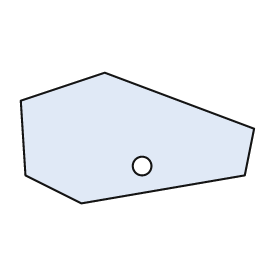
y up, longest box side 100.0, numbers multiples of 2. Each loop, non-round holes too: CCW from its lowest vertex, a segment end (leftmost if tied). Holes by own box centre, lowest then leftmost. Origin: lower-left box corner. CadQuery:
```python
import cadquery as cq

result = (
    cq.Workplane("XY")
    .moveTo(26.0, 0.0)
    .lineTo(96.0, 12.0)
    .lineTo(100.0, 32.0)
    .lineTo(36.0, 56.0)
    .lineTo(0.0, 44.0)
    .lineTo(2.0, 12.0)
    .close()
    .moveTo(52.0, 16.0)
    .circle(4.0)
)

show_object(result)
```